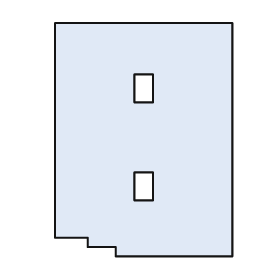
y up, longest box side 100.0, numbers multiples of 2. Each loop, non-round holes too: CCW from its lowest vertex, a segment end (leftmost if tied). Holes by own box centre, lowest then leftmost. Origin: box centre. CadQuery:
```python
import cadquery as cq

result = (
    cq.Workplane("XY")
    .moveTo(-12.0, -50.0)
    .lineTo(38.0, -50.0)
    .lineTo(38.0, 50.0)
    .lineTo(-38.0, 50.0)
    .lineTo(-38.0, -42.0)
    .lineTo(-24.0, -42.0)
    .lineTo(-24.0, -46.0)
    .lineTo(-12.0, -46.0)
    .close()
    .moveTo(-4.0, -26.0)
    .lineTo(4.0, -26.0)
    .lineTo(4.0, -14.0)
    .lineTo(-4.0, -14.0)
    .close()
    .moveTo(-4.0, 16.0)
    .lineTo(4.0, 16.0)
    .lineTo(4.0, 28.0)
    .lineTo(-4.0, 28.0)
    .close()
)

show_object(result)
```